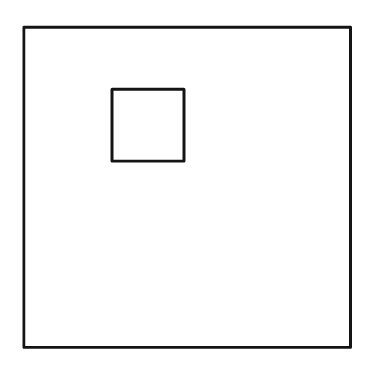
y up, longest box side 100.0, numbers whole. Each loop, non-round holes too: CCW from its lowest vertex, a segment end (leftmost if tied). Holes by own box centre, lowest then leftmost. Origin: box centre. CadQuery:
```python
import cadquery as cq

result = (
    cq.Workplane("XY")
    .moveTo(-50.0, -49.0)
    .lineTo(50.0, -49.0)
    .lineTo(50.0, 49.0)
    .lineTo(-50.0, 49.0)
    .close()
    .moveTo(-23.0, 8.0)
    .lineTo(-1.0, 8.0)
    .lineTo(-1.0, 30.0)
    .lineTo(-23.0, 30.0)
    .close()
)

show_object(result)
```